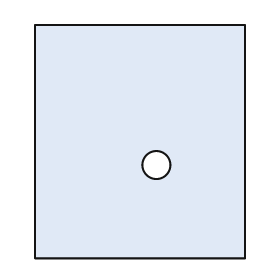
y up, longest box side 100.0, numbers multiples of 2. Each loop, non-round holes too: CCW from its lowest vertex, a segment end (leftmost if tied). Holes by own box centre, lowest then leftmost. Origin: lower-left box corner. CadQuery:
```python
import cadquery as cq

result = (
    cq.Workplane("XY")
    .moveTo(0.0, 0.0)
    .lineTo(90.0, 0.0)
    .lineTo(90.0, 100.0)
    .lineTo(0.0, 100.0)
    .close()
    .moveTo(52.0, 40.0)
    .circle(6.0)
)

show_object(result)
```